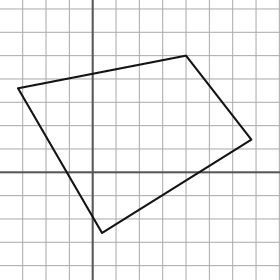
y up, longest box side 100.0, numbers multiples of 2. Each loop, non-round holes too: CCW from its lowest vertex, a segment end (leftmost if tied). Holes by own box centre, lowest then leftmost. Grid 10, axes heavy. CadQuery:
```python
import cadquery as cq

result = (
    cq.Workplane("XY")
    .moveTo(4.0, -26.0)
    .lineTo(68.0, 14.0)
    .lineTo(40.0, 50.0)
    .lineTo(-32.0, 36.0)
    .close()
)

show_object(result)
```